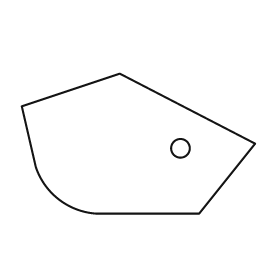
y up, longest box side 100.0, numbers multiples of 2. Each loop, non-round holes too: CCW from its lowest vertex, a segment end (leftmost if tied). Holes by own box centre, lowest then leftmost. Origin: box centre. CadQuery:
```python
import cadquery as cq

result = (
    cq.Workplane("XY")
    .moveTo(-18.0, -30.0)
    .lineTo(26.0, -30.0)
    .lineTo(50.0, 0.0)
    .lineTo(-8.0, 30.0)
    .lineTo(-50.0, 16.0)
    .lineTo(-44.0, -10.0)
    .threePointArc((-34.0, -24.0), (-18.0, -30.0))
    .close()
    .moveTo(18.0, -2.0)
    .circle(4.0)
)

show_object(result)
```